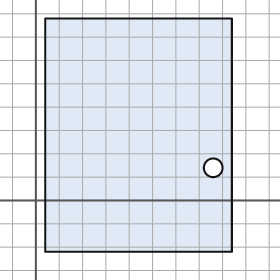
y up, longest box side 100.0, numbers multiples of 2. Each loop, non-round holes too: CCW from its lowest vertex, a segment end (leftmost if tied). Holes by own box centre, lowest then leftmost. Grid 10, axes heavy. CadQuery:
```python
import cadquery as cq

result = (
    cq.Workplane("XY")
    .moveTo(4.0, -22.0)
    .lineTo(84.0, -22.0)
    .lineTo(84.0, 78.0)
    .lineTo(4.0, 78.0)
    .close()
    .moveTo(76.0, 14.0)
    .circle(4.0)
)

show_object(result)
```